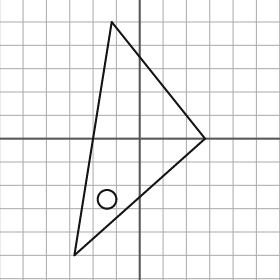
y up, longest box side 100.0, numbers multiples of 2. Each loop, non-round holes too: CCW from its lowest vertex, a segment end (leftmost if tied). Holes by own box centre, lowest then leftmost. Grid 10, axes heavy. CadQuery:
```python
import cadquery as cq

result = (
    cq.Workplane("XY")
    .moveTo(-28.0, -50.0)
    .lineTo(28.0, 0.0)
    .lineTo(-12.0, 50.0)
    .close()
    .moveTo(-14.0, -26.0)
    .circle(4.0)
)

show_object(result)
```